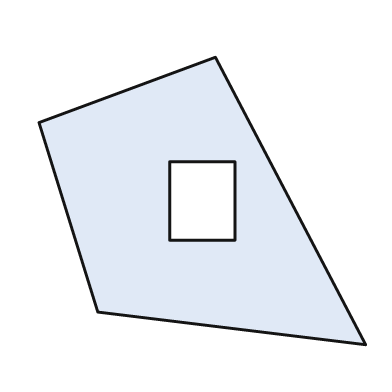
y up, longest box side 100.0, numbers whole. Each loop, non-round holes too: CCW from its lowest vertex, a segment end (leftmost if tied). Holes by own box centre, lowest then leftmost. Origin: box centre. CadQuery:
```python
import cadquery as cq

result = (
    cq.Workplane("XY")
    .moveTo(50.0, -44.0)
    .lineTo(4.0, 44.0)
    .lineTo(-50.0, 24.0)
    .lineTo(-32.0, -34.0)
    .close()
    .moveTo(-10.0, -12.0)
    .lineTo(10.0, -12.0)
    .lineTo(10.0, 12.0)
    .lineTo(-10.0, 12.0)
    .close()
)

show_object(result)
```